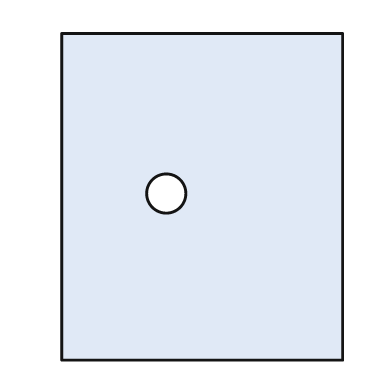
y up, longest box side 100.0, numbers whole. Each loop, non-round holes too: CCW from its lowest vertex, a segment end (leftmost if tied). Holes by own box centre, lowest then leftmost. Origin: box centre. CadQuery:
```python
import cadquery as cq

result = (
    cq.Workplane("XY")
    .moveTo(-43.0, -50.0)
    .lineTo(43.0, -50.0)
    .lineTo(43.0, 50.0)
    .lineTo(-43.0, 50.0)
    .close()
    .moveTo(-11.0, 1.0)
    .circle(6.0)
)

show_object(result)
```